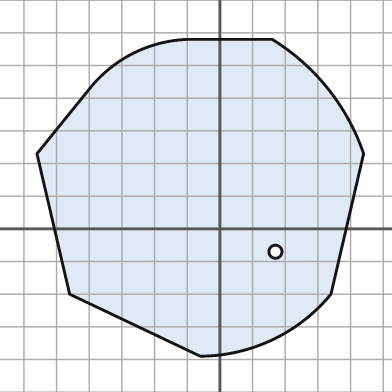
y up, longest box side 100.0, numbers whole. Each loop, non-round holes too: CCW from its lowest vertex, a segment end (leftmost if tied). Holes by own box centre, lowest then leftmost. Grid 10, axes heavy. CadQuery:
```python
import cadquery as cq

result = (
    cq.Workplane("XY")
    .moveTo(-6.0, -39.0)
    .threePointArc((16.0, -34.0), (34.0, -20.0))
    .lineTo(44.0, 23.0)
    .threePointArc((33.0, 43.0), (16.0, 58.0))
    .lineTo(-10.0, 58.0)
    .threePointArc((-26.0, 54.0), (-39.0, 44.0))
    .lineTo(-56.0, 23.0)
    .lineTo(-46.0, -20.0)
    .close()
    .moveTo(17.0, -7.0)
    .circle(2.0)
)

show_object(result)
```